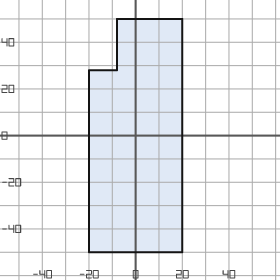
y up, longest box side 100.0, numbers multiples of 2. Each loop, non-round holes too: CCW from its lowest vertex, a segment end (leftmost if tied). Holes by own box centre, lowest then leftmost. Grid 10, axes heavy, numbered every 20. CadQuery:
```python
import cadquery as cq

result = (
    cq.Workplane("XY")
    .moveTo(-20.0, -50.0)
    .lineTo(20.0, -50.0)
    .lineTo(20.0, 50.0)
    .lineTo(-8.0, 50.0)
    .lineTo(-8.0, 28.0)
    .lineTo(-20.0, 28.0)
    .close()
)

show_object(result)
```